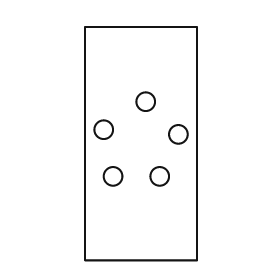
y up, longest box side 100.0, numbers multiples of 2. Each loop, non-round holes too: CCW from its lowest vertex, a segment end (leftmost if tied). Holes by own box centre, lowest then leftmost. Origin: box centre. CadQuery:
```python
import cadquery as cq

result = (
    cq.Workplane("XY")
    .moveTo(-24.0, -50.0)
    .lineTo(24.0, -50.0)
    .lineTo(24.0, 50.0)
    .lineTo(-24.0, 50.0)
    .close()
    .moveTo(-12.0, -14.0)
    .circle(4.0)
    .moveTo(8.0, -14.0)
    .circle(4.0)
    .moveTo(16.0, 4.0)
    .circle(4.0)
    .moveTo(-16.0, 6.0)
    .circle(4.0)
    .moveTo(2.0, 18.0)
    .circle(4.0)
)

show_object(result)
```